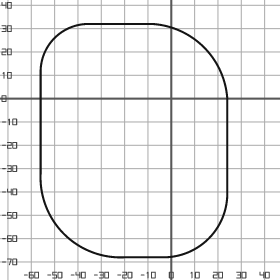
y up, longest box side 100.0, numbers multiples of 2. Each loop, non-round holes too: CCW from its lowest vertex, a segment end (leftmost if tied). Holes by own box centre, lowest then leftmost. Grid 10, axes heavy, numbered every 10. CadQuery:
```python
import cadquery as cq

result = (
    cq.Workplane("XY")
    .moveTo(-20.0, -68.0)
    .lineTo(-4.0, -68.0)
    .threePointArc((16.0, -60.0), (24.0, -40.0))
    .lineTo(24.0, 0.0)
    .threePointArc((14.0, 22.0), (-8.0, 32.0))
    .lineTo(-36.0, 32.0)
    .threePointArc((-50.0, 26.0), (-56.0, 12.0))
    .lineTo(-56.0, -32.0)
    .threePointArc((-46.0, -58.0), (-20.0, -68.0))
    .close()
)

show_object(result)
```